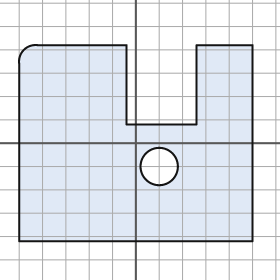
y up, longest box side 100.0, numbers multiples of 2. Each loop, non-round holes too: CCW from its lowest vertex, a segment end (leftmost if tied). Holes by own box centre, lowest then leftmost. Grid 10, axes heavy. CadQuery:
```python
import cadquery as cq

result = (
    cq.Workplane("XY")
    .moveTo(-50.0, -42.0)
    .lineTo(50.0, -42.0)
    .lineTo(50.0, 42.0)
    .lineTo(26.0, 42.0)
    .lineTo(26.0, 8.0)
    .lineTo(-4.0, 8.0)
    .lineTo(-4.0, 42.0)
    .lineTo(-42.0, 42.0)
    .threePointArc((-48.0, 40.0), (-50.0, 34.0))
    .close()
    .moveTo(10.0, -10.0)
    .circle(8.0)
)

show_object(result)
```